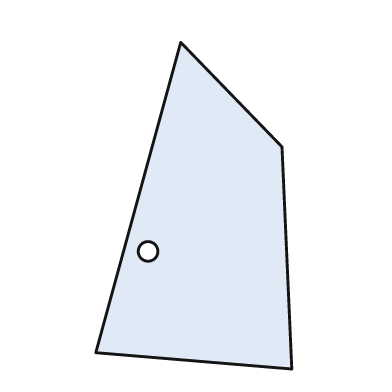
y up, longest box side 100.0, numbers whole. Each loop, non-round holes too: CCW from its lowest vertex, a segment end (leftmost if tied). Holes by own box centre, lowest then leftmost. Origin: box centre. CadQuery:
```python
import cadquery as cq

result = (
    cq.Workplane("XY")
    .moveTo(30.0, -50.0)
    .lineTo(27.0, 18.0)
    .lineTo(-4.0, 50.0)
    .lineTo(-30.0, -45.0)
    .close()
    .moveTo(-14.0, -14.0)
    .circle(3.0)
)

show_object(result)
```